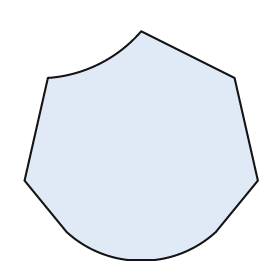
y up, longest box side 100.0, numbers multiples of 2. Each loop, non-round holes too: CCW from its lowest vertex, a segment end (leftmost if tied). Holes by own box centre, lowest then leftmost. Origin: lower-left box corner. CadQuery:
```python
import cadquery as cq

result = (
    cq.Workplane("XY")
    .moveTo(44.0, 0.0)
    .lineTo(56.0, 0.0)
    .threePointArc((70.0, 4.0), (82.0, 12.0))
    .lineTo(100.0, 34.0)
    .lineTo(90.0, 78.0)
    .lineTo(50.0, 98.0)
    .threePointArc((32.0, 84.0), (10.0, 78.0))
    .lineTo(0.0, 34.0)
    .lineTo(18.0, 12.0)
    .threePointArc((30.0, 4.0), (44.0, 0.0))
    .close()
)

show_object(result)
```